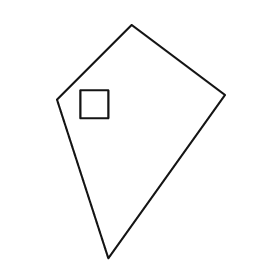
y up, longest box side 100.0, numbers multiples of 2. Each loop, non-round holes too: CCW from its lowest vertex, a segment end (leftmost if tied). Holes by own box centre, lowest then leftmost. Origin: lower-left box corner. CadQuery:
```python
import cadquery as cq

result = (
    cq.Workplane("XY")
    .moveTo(22.0, 0.0)
    .lineTo(72.0, 70.0)
    .lineTo(32.0, 100.0)
    .lineTo(0.0, 68.0)
    .close()
    .moveTo(10.0, 60.0)
    .lineTo(22.0, 60.0)
    .lineTo(22.0, 72.0)
    .lineTo(10.0, 72.0)
    .close()
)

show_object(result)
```